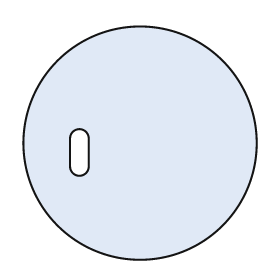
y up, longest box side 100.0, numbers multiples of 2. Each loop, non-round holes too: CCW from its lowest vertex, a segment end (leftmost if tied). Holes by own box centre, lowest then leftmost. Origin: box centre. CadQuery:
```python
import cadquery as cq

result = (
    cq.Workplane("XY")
    .moveTo(0.0, 0.0)
    .circle(50.0)
    .moveTo(-30.0, -10.0)
    .threePointArc((-26.0, -14.0), (-22.0, -10.0))
    .lineTo(-22.0, 2.0)
    .threePointArc((-26.0, 6.0), (-30.0, 2.0))
    .close()
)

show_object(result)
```